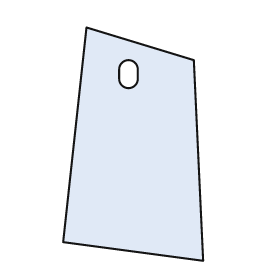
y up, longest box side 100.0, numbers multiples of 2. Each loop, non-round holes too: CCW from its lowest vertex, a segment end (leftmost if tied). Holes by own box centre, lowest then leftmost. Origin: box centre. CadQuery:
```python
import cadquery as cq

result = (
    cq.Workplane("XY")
    .moveTo(30.0, -50.0)
    .lineTo(26.0, 36.0)
    .lineTo(-20.0, 50.0)
    .lineTo(-30.0, -42.0)
    .close()
    .moveTo(-6.0, 28.0)
    .threePointArc((-2.0, 24.0), (2.0, 28.0))
    .lineTo(2.0, 32.0)
    .threePointArc((-2.0, 36.0), (-6.0, 32.0))
    .close()
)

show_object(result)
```